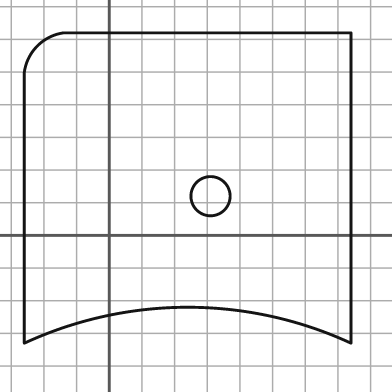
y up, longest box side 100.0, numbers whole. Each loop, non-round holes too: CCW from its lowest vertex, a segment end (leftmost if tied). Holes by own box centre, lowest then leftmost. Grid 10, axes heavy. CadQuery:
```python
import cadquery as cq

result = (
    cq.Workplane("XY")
    .moveTo(-26.0, -33.0)
    .threePointArc((24.0, -22.0), (74.0, -33.0))
    .lineTo(74.0, 62.0)
    .lineTo(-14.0, 62.0)
    .threePointArc((-22.0, 58.0), (-26.0, 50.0))
    .close()
    .moveTo(31.0, 12.0)
    .circle(6.0)
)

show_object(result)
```